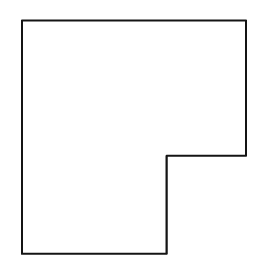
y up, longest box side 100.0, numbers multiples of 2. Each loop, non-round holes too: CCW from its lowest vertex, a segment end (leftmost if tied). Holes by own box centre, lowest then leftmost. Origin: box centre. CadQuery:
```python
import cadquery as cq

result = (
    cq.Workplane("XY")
    .moveTo(-48.0, -50.0)
    .lineTo(14.0, -50.0)
    .lineTo(14.0, -8.0)
    .lineTo(48.0, -8.0)
    .lineTo(48.0, 50.0)
    .lineTo(-48.0, 50.0)
    .close()
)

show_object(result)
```